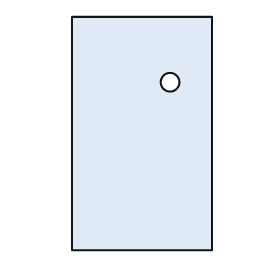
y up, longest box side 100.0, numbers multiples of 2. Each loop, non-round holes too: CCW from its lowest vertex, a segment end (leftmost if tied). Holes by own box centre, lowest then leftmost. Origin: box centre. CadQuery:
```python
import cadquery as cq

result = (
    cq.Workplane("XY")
    .moveTo(-30.0, -50.0)
    .lineTo(30.0, -50.0)
    .lineTo(30.0, 50.0)
    .lineTo(-30.0, 50.0)
    .close()
    .moveTo(12.0, 22.0)
    .circle(4.0)
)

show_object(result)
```